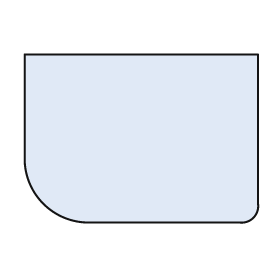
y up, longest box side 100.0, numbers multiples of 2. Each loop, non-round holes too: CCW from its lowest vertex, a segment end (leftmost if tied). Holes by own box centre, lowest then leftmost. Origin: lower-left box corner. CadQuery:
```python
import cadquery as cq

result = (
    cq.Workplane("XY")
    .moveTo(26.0, 0.0)
    .lineTo(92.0, 0.0)
    .threePointArc((98.0, 2.0), (100.0, 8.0))
    .lineTo(100.0, 72.0)
    .lineTo(0.0, 72.0)
    .lineTo(0.0, 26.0)
    .threePointArc((8.0, 8.0), (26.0, 0.0))
    .close()
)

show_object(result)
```